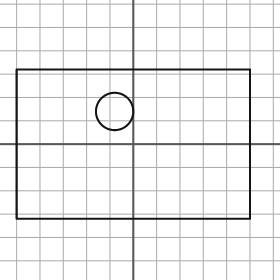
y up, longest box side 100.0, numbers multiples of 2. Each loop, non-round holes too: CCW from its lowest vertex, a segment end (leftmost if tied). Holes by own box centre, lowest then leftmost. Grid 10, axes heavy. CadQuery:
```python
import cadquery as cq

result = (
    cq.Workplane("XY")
    .moveTo(-50.0, -32.0)
    .lineTo(50.0, -32.0)
    .lineTo(50.0, 32.0)
    .lineTo(-50.0, 32.0)
    .close()
    .moveTo(-8.0, 14.0)
    .circle(8.0)
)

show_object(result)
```